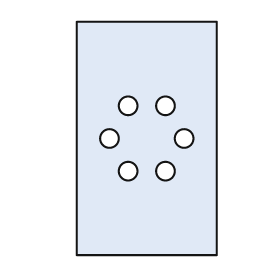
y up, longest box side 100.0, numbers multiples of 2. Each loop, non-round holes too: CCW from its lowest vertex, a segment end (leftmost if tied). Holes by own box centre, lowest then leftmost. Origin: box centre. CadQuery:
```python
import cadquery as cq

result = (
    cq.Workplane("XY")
    .moveTo(-30.0, -50.0)
    .lineTo(30.0, -50.0)
    .lineTo(30.0, 50.0)
    .lineTo(-30.0, 50.0)
    .close()
    .moveTo(-8.0, -14.0)
    .circle(4.0)
    .moveTo(8.0, -14.0)
    .circle(4.0)
    .moveTo(-16.0, 0.0)
    .circle(4.0)
    .moveTo(16.0, 0.0)
    .circle(4.0)
    .moveTo(-8.0, 14.0)
    .circle(4.0)
    .moveTo(8.0, 14.0)
    .circle(4.0)
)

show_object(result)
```